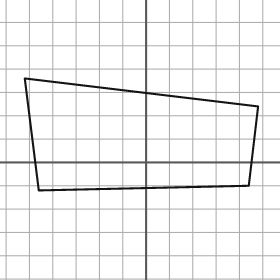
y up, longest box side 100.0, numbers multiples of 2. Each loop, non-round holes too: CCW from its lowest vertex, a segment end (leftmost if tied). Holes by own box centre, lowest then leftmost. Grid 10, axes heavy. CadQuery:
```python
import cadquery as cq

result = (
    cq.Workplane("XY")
    .moveTo(-46.0, -12.0)
    .lineTo(44.0, -10.0)
    .lineTo(48.0, 24.0)
    .lineTo(-52.0, 36.0)
    .close()
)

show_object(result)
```